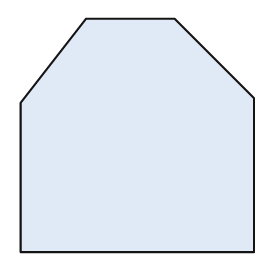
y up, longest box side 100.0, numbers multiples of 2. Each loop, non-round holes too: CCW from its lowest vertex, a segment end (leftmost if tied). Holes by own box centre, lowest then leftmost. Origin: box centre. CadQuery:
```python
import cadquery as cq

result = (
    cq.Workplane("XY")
    .moveTo(-50.0, -50.0)
    .lineTo(50.0, -50.0)
    .lineTo(50.0, 16.0)
    .lineTo(16.0, 50.0)
    .lineTo(-22.0, 50.0)
    .lineTo(-50.0, 14.0)
    .close()
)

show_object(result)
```